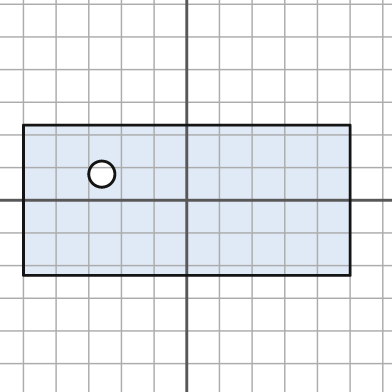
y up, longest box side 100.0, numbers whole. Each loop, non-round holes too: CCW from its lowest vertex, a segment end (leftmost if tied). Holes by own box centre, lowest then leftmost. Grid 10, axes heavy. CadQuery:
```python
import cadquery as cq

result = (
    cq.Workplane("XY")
    .moveTo(-50.0, -23.0)
    .lineTo(50.0, -23.0)
    .lineTo(50.0, 23.0)
    .lineTo(-50.0, 23.0)
    .close()
    .moveTo(-26.0, 8.0)
    .circle(4.0)
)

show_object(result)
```